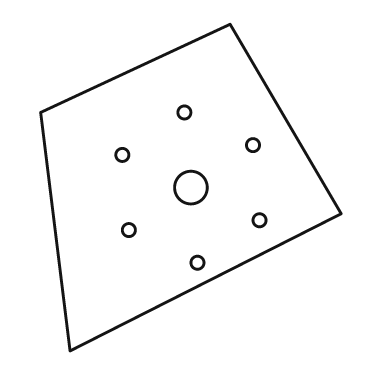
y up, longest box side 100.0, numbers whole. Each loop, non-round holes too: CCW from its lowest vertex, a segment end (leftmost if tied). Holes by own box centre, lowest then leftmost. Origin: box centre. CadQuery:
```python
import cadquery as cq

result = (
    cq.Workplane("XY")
    .moveTo(-37.0, -50.0)
    .lineTo(46.0, -8.0)
    .lineTo(12.0, 50.0)
    .lineTo(-46.0, 23.0)
    .close()
    .moveTo(2.0, -23.0)
    .circle(2.0)
    .moveTo(-19.0, -13.0)
    .circle(2.0)
    .moveTo(21.0, -10.0)
    .circle(2.0)
    .moveTo(0.0, 0.0)
    .circle(5.0)
    .moveTo(-21.0, 10.0)
    .circle(2.0)
    .moveTo(19.0, 13.0)
    .circle(2.0)
    .moveTo(-2.0, 23.0)
    .circle(2.0)
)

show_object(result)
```